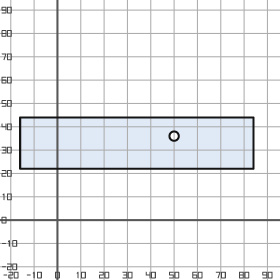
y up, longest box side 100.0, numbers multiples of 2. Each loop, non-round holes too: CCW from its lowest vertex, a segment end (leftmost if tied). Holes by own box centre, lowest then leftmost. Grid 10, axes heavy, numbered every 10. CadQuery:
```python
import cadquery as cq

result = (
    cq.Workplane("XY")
    .moveTo(-16.0, 22.0)
    .lineTo(84.0, 22.0)
    .lineTo(84.0, 44.0)
    .lineTo(-16.0, 44.0)
    .close()
    .moveTo(50.0, 36.0)
    .circle(2.0)
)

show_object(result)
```